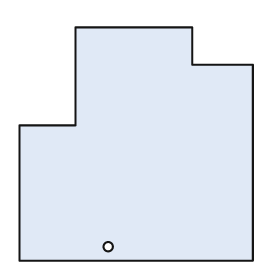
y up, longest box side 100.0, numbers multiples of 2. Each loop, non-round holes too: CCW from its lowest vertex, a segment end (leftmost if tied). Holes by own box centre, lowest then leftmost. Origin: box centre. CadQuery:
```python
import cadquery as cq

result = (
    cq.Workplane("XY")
    .moveTo(-50.0, -50.0)
    .lineTo(50.0, -50.0)
    .lineTo(50.0, 34.0)
    .lineTo(24.0, 34.0)
    .lineTo(24.0, 50.0)
    .lineTo(-26.0, 50.0)
    .lineTo(-26.0, 8.0)
    .lineTo(-50.0, 8.0)
    .close()
    .moveTo(-12.0, -44.0)
    .circle(2.0)
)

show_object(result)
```